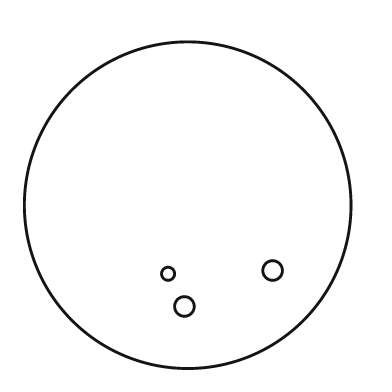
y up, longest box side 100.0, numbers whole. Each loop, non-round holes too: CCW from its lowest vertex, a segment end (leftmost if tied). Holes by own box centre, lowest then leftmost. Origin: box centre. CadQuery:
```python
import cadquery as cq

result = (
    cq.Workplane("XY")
    .moveTo(0.0, 0.0)
    .circle(50.0)
    .moveTo(-1.0, -31.0)
    .circle(3.0)
    .moveTo(-6.0, -21.0)
    .circle(2.0)
    .moveTo(26.0, -20.0)
    .circle(3.0)
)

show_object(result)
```